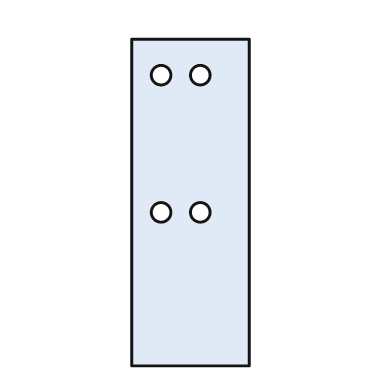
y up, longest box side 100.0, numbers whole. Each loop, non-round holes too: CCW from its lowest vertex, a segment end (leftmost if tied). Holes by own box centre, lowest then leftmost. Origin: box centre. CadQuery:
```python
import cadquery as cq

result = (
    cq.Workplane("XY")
    .moveTo(-18.0, -50.0)
    .lineTo(18.0, -50.0)
    .lineTo(18.0, 50.0)
    .lineTo(-18.0, 50.0)
    .close()
    .moveTo(-9.0, -3.0)
    .circle(3.0)
    .moveTo(3.0, -3.0)
    .circle(3.0)
    .moveTo(-9.0, 39.0)
    .circle(3.0)
    .moveTo(3.0, 39.0)
    .circle(3.0)
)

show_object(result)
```